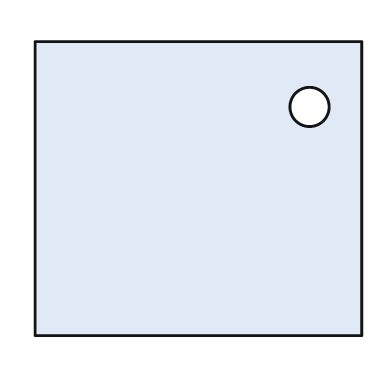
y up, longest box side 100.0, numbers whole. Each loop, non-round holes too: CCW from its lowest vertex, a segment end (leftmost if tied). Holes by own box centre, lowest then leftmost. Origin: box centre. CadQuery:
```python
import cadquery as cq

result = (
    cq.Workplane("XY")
    .moveTo(-50.0, -45.0)
    .lineTo(50.0, -45.0)
    .lineTo(50.0, 45.0)
    .lineTo(-50.0, 45.0)
    .close()
    .moveTo(34.0, 25.0)
    .circle(6.0)
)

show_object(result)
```